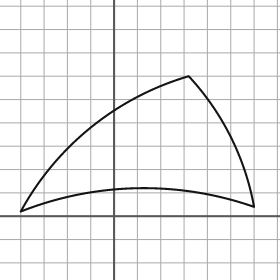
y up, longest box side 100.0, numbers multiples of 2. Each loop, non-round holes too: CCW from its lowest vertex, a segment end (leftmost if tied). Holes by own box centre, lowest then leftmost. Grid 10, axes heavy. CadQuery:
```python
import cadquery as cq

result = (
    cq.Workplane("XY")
    .moveTo(-40.0, 2.0)
    .threePointArc((10.0, 12.0), (60.0, 4.0))
    .threePointArc((50.0, 34.0), (32.0, 60.0))
    .threePointArc((-10.0, 38.0), (-40.0, 2.0))
    .close()
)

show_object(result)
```